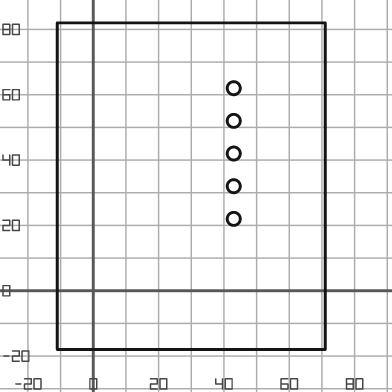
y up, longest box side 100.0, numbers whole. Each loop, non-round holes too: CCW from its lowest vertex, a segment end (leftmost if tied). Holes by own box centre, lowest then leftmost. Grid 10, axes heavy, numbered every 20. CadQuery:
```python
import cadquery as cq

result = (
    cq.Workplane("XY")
    .moveTo(-11.0, -18.0)
    .lineTo(71.0, -18.0)
    .lineTo(71.0, 82.0)
    .lineTo(-11.0, 82.0)
    .close()
    .moveTo(43.0, 22.0)
    .circle(2.0)
    .moveTo(43.0, 32.0)
    .circle(2.0)
    .moveTo(43.0, 42.0)
    .circle(2.0)
    .moveTo(43.0, 52.0)
    .circle(2.0)
    .moveTo(43.0, 62.0)
    .circle(2.0)
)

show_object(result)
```